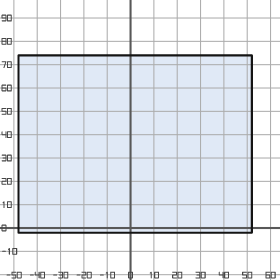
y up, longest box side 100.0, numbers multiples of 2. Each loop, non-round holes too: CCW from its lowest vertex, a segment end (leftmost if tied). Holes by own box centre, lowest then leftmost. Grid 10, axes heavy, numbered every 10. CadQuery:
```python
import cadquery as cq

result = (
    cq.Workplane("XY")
    .moveTo(-48.0, -2.0)
    .lineTo(52.0, -2.0)
    .lineTo(52.0, 74.0)
    .lineTo(-48.0, 74.0)
    .close()
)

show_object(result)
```